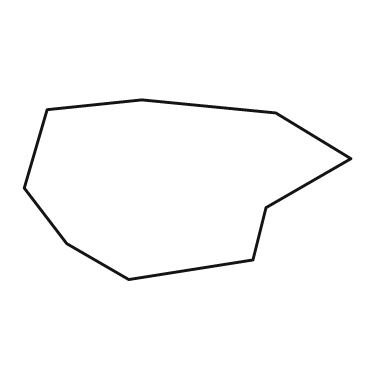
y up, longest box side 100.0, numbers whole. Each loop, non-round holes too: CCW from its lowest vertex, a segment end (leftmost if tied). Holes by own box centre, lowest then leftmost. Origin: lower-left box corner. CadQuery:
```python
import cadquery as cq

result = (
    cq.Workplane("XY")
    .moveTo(32.0, 0.0)
    .lineTo(70.0, 6.0)
    .lineTo(74.0, 22.0)
    .lineTo(100.0, 37.0)
    .lineTo(77.0, 51.0)
    .lineTo(36.0, 55.0)
    .lineTo(7.0, 52.0)
    .lineTo(0.0, 28.0)
    .lineTo(13.0, 11.0)
    .close()
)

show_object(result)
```